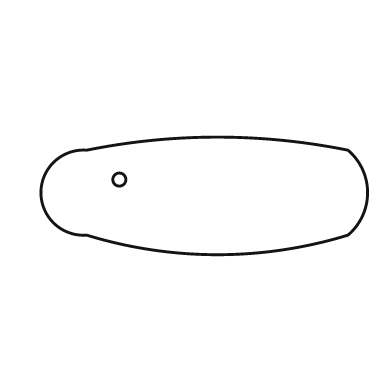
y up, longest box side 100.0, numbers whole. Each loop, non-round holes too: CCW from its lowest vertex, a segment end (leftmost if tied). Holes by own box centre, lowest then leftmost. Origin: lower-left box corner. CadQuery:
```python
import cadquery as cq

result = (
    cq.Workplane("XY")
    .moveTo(14.0, 6.0)
    .threePointArc((54.0, 0.0), (94.0, 6.0))
    .threePointArc((100.0, 19.0), (94.0, 32.0))
    .threePointArc((54.0, 36.0), (14.0, 32.0))
    .threePointArc((0.0, 19.0), (14.0, 6.0))
    .close()
    .moveTo(24.0, 23.0)
    .circle(2.0)
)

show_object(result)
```